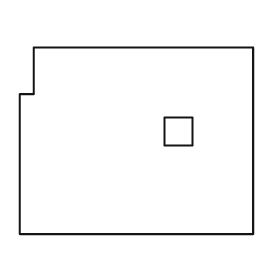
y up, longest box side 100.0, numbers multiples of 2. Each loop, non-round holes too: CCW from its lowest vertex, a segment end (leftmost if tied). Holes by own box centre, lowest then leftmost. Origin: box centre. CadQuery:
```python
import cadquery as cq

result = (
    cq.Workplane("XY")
    .moveTo(-50.0, -40.0)
    .lineTo(50.0, -40.0)
    .lineTo(50.0, 40.0)
    .lineTo(-44.0, 40.0)
    .lineTo(-44.0, 20.0)
    .lineTo(-50.0, 20.0)
    .close()
    .moveTo(12.0, -2.0)
    .lineTo(24.0, -2.0)
    .lineTo(24.0, 10.0)
    .lineTo(12.0, 10.0)
    .close()
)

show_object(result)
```